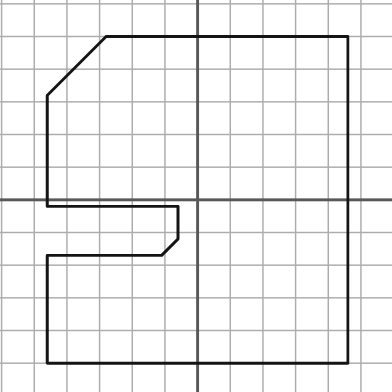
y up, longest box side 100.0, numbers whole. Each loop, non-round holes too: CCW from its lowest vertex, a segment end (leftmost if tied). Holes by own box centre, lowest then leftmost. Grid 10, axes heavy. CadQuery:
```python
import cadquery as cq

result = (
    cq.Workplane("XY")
    .moveTo(-46.0, -50.0)
    .lineTo(46.0, -50.0)
    .lineTo(46.0, 50.0)
    .lineTo(-28.0, 50.0)
    .lineTo(-46.0, 32.0)
    .lineTo(-46.0, -2.0)
    .lineTo(-6.0, -2.0)
    .lineTo(-6.0, -12.0)
    .lineTo(-11.0, -17.0)
    .lineTo(-46.0, -17.0)
    .close()
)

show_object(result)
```